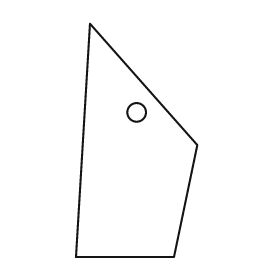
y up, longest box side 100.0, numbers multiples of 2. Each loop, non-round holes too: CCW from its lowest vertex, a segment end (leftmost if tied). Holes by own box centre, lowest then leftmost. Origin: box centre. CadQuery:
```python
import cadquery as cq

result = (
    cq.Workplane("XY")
    .moveTo(-26.0, -50.0)
    .lineTo(16.0, -50.0)
    .lineTo(26.0, -2.0)
    .lineTo(-20.0, 50.0)
    .close()
    .moveTo(0.0, 12.0)
    .circle(4.0)
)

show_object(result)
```